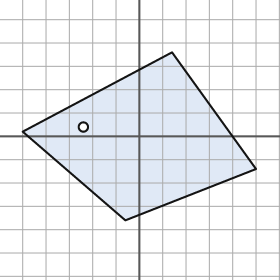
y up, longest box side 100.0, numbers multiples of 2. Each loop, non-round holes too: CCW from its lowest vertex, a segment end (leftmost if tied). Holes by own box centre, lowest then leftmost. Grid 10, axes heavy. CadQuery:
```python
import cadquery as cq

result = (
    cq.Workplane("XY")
    .moveTo(-6.0, -36.0)
    .lineTo(50.0, -14.0)
    .lineTo(14.0, 36.0)
    .lineTo(-50.0, 2.0)
    .close()
    .moveTo(-24.0, 4.0)
    .circle(2.0)
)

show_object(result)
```